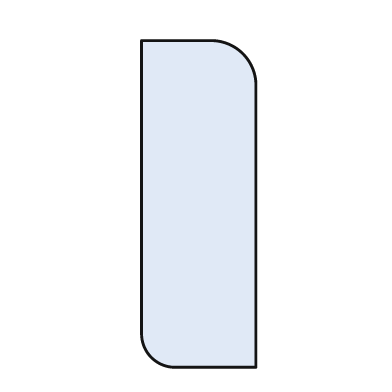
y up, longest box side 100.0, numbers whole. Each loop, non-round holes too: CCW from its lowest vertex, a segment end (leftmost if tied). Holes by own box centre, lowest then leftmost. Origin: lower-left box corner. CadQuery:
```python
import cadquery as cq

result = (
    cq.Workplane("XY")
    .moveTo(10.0, 0.0)
    .lineTo(35.0, 0.0)
    .lineTo(35.0, 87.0)
    .threePointArc((31.0, 96.0), (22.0, 100.0))
    .lineTo(0.0, 100.0)
    .lineTo(0.0, 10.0)
    .threePointArc((3.0, 3.0), (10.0, 0.0))
    .close()
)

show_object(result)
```